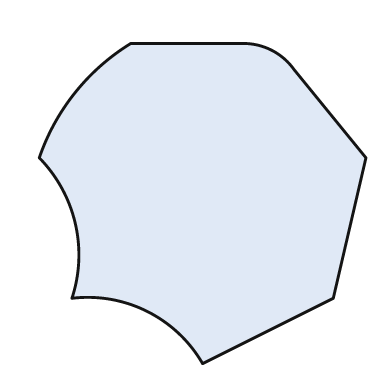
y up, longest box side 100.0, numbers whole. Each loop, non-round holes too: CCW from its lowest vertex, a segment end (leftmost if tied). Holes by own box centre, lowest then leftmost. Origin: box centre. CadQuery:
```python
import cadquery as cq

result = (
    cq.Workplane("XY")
    .moveTo(0.0, -49.0)
    .lineTo(40.0, -29.0)
    .lineTo(50.0, 14.0)
    .lineTo(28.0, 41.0)
    .threePointArc((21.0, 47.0), (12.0, 49.0))
    .lineTo(-22.0, 49.0)
    .threePointArc((-39.0, 34.0), (-50.0, 14.0))
    .threePointArc((-39.0, -6.0), (-40.0, -29.0))
    .threePointArc((-17.0, -33.0), (0.0, -49.0))
    .close()
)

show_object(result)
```